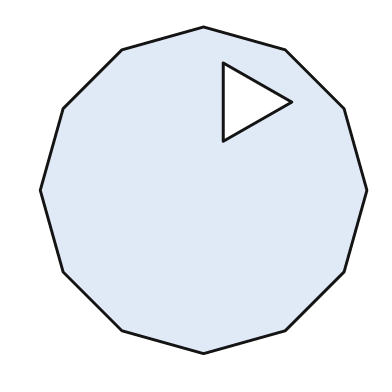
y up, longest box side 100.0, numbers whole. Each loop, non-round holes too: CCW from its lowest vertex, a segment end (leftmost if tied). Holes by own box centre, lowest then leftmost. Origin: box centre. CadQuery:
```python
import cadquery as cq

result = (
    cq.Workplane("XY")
    .moveTo(0.0, -50.0)
    .lineTo(25.0, -43.0)
    .lineTo(43.0, -25.0)
    .lineTo(50.0, 0.0)
    .lineTo(43.0, 25.0)
    .lineTo(25.0, 43.0)
    .lineTo(0.0, 50.0)
    .lineTo(-25.0, 43.0)
    .lineTo(-43.0, 25.0)
    .lineTo(-50.0, 0.0)
    .lineTo(-43.0, -25.0)
    .lineTo(-25.0, -43.0)
    .close()
    .moveTo(6.0, 15.0)
    .lineTo(27.0, 27.0)
    .lineTo(6.0, 39.0)
    .close()
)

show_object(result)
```